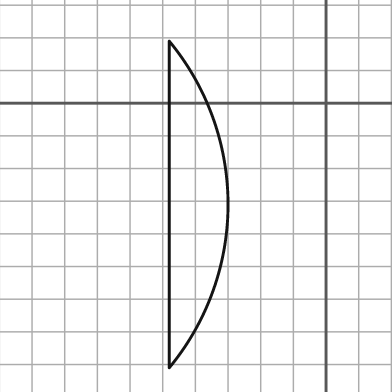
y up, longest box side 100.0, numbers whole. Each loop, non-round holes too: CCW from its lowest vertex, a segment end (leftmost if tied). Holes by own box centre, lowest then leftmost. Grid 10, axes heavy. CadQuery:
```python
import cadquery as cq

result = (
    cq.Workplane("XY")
    .moveTo(-48.0, -81.0)
    .threePointArc((-30.0, -31.0), (-48.0, 19.0))
    .close()
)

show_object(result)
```